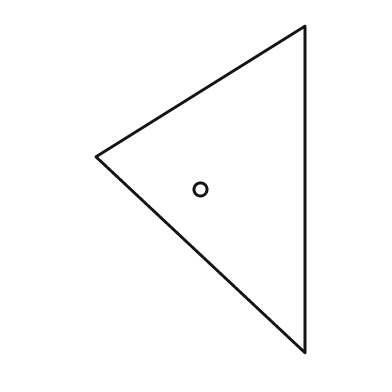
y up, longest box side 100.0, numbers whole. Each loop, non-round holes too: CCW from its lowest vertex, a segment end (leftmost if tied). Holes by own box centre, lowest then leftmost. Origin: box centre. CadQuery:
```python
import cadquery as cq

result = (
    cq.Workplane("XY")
    .moveTo(32.0, -50.0)
    .lineTo(32.0, 50.0)
    .lineTo(-32.0, 10.0)
    .close()
    .moveTo(0.0, 0.0)
    .circle(2.0)
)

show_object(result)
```